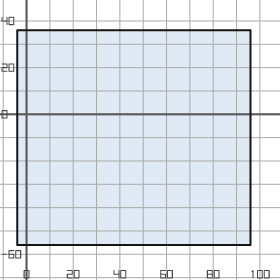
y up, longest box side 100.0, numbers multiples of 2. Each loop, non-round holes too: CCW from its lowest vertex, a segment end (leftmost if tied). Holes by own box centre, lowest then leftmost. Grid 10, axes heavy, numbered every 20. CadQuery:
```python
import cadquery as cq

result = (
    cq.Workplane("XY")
    .moveTo(-4.0, -56.0)
    .lineTo(96.0, -56.0)
    .lineTo(96.0, 36.0)
    .lineTo(-4.0, 36.0)
    .close()
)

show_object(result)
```